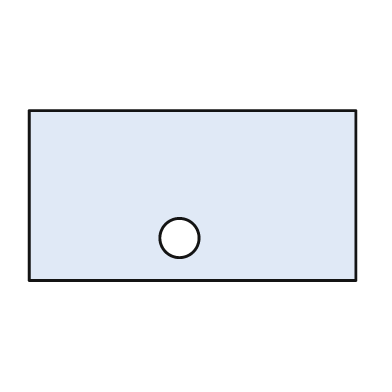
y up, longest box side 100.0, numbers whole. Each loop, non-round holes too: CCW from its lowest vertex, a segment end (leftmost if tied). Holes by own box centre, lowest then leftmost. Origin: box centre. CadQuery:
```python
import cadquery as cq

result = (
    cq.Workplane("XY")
    .moveTo(-50.0, -26.0)
    .lineTo(50.0, -26.0)
    .lineTo(50.0, 26.0)
    .lineTo(-50.0, 26.0)
    .close()
    .moveTo(-4.0, -13.0)
    .circle(6.0)
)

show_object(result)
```